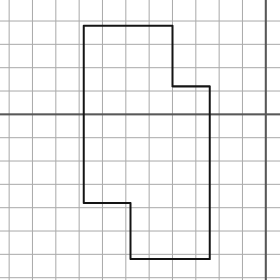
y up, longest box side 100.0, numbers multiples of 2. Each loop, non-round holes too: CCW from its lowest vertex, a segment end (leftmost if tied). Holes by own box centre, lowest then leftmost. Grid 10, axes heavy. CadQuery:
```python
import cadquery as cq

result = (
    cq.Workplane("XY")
    .moveTo(-58.0, -62.0)
    .lineTo(-24.0, -62.0)
    .lineTo(-24.0, 12.0)
    .lineTo(-40.0, 12.0)
    .lineTo(-40.0, 38.0)
    .lineTo(-78.0, 38.0)
    .lineTo(-78.0, -38.0)
    .lineTo(-58.0, -38.0)
    .close()
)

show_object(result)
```